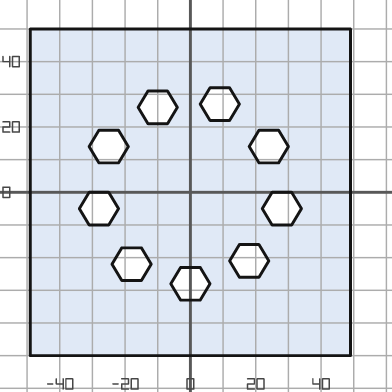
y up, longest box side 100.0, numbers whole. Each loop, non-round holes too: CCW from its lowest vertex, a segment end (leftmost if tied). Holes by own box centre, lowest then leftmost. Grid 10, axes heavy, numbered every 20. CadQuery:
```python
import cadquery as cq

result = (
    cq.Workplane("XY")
    .moveTo(-49.0, -50.0)
    .lineTo(49.0, -50.0)
    .lineTo(49.0, 50.0)
    .lineTo(-49.0, 50.0)
    .close()
    .moveTo(-3.0, -33.0)
    .lineTo(3.0, -33.0)
    .lineTo(6.0, -28.0)
    .lineTo(3.0, -23.0)
    .lineTo(-3.0, -23.0)
    .lineTo(-6.0, -28.0)
    .close()
    .moveTo(-21.0, -27.0)
    .lineTo(-15.0, -27.0)
    .lineTo(-12.0, -22.0)
    .lineTo(-15.0, -17.0)
    .lineTo(-21.0, -17.0)
    .lineTo(-24.0, -22.0)
    .close()
    .moveTo(15.0, -26.0)
    .lineTo(21.0, -26.0)
    .lineTo(24.0, -21.0)
    .lineTo(21.0, -16.0)
    .lineTo(15.0, -16.0)
    .lineTo(12.0, -21.0)
    .close()
    .moveTo(-31.0, -10.0)
    .lineTo(-25.0, -10.0)
    .lineTo(-22.0, -5.0)
    .lineTo(-25.0, 0.0)
    .lineTo(-31.0, 0.0)
    .lineTo(-34.0, -5.0)
    .close()
    .moveTo(25.0, -10.0)
    .lineTo(31.0, -10.0)
    .lineTo(34.0, -5.0)
    .lineTo(31.0, 0.0)
    .lineTo(25.0, 0.0)
    .lineTo(22.0, -5.0)
    .close()
    .moveTo(-28.0, 9.0)
    .lineTo(-22.0, 9.0)
    .lineTo(-19.0, 14.0)
    .lineTo(-22.0, 19.0)
    .lineTo(-28.0, 19.0)
    .lineTo(-31.0, 14.0)
    .close()
    .moveTo(21.0, 9.0)
    .lineTo(27.0, 9.0)
    .lineTo(30.0, 14.0)
    .lineTo(27.0, 19.0)
    .lineTo(21.0, 19.0)
    .lineTo(18.0, 14.0)
    .close()
    .moveTo(-13.0, 21.0)
    .lineTo(-7.0, 21.0)
    .lineTo(-4.0, 26.0)
    .lineTo(-7.0, 31.0)
    .lineTo(-13.0, 31.0)
    .lineTo(-16.0, 26.0)
    .close()
    .moveTo(6.0, 22.0)
    .lineTo(12.0, 22.0)
    .lineTo(15.0, 27.0)
    .lineTo(12.0, 32.0)
    .lineTo(6.0, 32.0)
    .lineTo(3.0, 27.0)
    .close()
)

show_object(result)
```